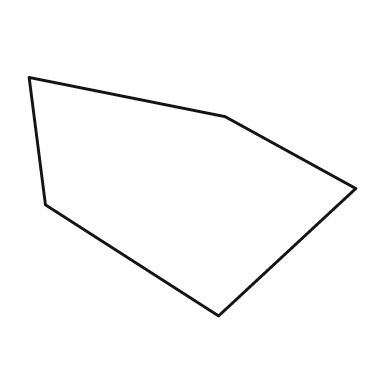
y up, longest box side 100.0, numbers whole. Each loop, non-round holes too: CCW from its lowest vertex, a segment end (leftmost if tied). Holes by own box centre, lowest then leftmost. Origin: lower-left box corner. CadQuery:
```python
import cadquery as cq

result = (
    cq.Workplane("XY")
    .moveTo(58.0, 0.0)
    .lineTo(100.0, 39.0)
    .lineTo(60.0, 61.0)
    .lineTo(0.0, 73.0)
    .lineTo(5.0, 34.0)
    .close()
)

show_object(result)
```